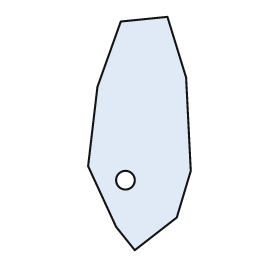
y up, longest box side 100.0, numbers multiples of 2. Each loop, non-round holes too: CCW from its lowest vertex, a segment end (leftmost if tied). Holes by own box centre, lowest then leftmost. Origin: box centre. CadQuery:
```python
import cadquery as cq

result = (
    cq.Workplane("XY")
    .moveTo(-2.0, -50.0)
    .lineTo(16.0, -36.0)
    .lineTo(22.0, -16.0)
    .lineTo(20.0, 24.0)
    .lineTo(12.0, 50.0)
    .lineTo(-8.0, 48.0)
    .lineTo(-18.0, 20.0)
    .lineTo(-22.0, -14.0)
    .lineTo(-10.0, -40.0)
    .close()
    .moveTo(-6.0, -20.0)
    .circle(4.0)
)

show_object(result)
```